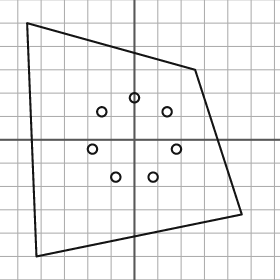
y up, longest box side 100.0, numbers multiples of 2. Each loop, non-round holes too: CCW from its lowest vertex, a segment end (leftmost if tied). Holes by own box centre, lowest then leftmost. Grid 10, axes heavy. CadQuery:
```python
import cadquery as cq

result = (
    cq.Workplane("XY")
    .moveTo(-42.0, -50.0)
    .lineTo(46.0, -32.0)
    .lineTo(26.0, 30.0)
    .lineTo(-46.0, 50.0)
    .close()
    .moveTo(-8.0, -16.0)
    .circle(2.0)
    .moveTo(8.0, -16.0)
    .circle(2.0)
    .moveTo(-18.0, -4.0)
    .circle(2.0)
    .moveTo(18.0, -4.0)
    .circle(2.0)
    .moveTo(-14.0, 12.0)
    .circle(2.0)
    .moveTo(14.0, 12.0)
    .circle(2.0)
    .moveTo(0.0, 18.0)
    .circle(2.0)
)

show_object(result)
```